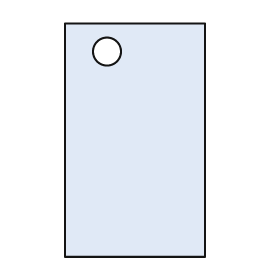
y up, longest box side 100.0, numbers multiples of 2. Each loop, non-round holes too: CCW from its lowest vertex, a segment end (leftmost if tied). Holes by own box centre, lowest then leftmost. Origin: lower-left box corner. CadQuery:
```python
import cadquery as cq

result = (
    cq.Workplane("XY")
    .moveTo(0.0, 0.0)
    .lineTo(60.0, 0.0)
    .lineTo(60.0, 100.0)
    .lineTo(0.0, 100.0)
    .close()
    .moveTo(18.0, 88.0)
    .circle(6.0)
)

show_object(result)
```